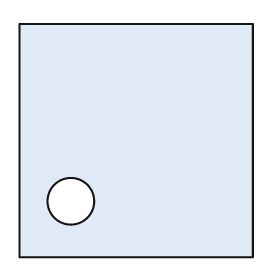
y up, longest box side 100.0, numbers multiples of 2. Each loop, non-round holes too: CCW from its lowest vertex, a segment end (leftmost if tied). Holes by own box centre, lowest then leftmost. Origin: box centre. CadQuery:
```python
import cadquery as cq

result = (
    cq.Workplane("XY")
    .moveTo(-50.0, -50.0)
    .lineTo(50.0, -50.0)
    .lineTo(50.0, 50.0)
    .lineTo(-50.0, 50.0)
    .close()
    .moveTo(-28.0, -26.0)
    .circle(10.0)
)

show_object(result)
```